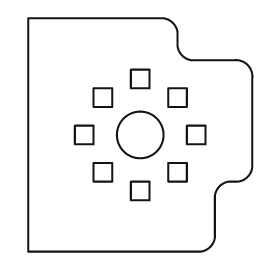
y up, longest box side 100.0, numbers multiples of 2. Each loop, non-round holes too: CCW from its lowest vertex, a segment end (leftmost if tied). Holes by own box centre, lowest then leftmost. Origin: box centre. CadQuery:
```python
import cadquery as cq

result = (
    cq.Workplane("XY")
    .moveTo(-48.0, -50.0)
    .lineTo(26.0, -50.0)
    .threePointArc((30.0, -48.0), (32.0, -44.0))
    .lineTo(32.0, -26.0)
    .threePointArc((34.0, -22.0), (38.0, -20.0))
    .lineTo(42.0, -20.0)
    .threePointArc((46.0, -18.0), (48.0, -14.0))
    .lineTo(48.0, 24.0)
    .threePointArc((46.0, 30.0), (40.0, 32.0))
    .lineTo(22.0, 32.0)
    .threePointArc((18.0, 34.0), (16.0, 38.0))
    .lineTo(16.0, 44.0)
    .threePointArc((14.0, 48.0), (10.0, 50.0))
    .lineTo(-48.0, 50.0)
    .close()
    .moveTo(-4.0, -28.0)
    .lineTo(4.0, -28.0)
    .lineTo(4.0, -20.0)
    .lineTo(-4.0, -20.0)
    .close()
    .moveTo(-20.0, -20.0)
    .lineTo(-12.0, -20.0)
    .lineTo(-12.0, -12.0)
    .lineTo(-20.0, -12.0)
    .close()
    .moveTo(12.0, -20.0)
    .lineTo(20.0, -20.0)
    .lineTo(20.0, -12.0)
    .lineTo(12.0, -12.0)
    .close()
    .moveTo(-28.0, -4.0)
    .lineTo(-20.0, -4.0)
    .lineTo(-20.0, 4.0)
    .lineTo(-28.0, 4.0)
    .close()
    .moveTo(0.0, 0.0)
    .circle(10.0)
    .moveTo(20.0, -4.0)
    .lineTo(28.0, -4.0)
    .lineTo(28.0, 4.0)
    .lineTo(20.0, 4.0)
    .close()
    .moveTo(-20.0, 12.0)
    .lineTo(-12.0, 12.0)
    .lineTo(-12.0, 20.0)
    .lineTo(-20.0, 20.0)
    .close()
    .moveTo(12.0, 12.0)
    .lineTo(20.0, 12.0)
    .lineTo(20.0, 20.0)
    .lineTo(12.0, 20.0)
    .close()
    .moveTo(-4.0, 20.0)
    .lineTo(4.0, 20.0)
    .lineTo(4.0, 28.0)
    .lineTo(-4.0, 28.0)
    .close()
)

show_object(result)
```